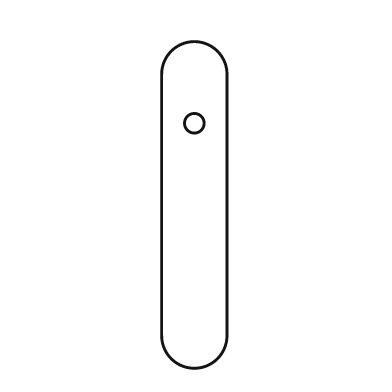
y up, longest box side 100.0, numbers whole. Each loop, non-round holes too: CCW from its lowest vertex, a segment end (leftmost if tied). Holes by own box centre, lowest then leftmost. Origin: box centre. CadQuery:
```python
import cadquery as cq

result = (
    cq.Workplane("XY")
    .moveTo(-10.0, -40.0)
    .threePointArc((0.0, -50.0), (10.0, -40.0))
    .lineTo(10.0, 40.0)
    .threePointArc((0.0, 50.0), (-10.0, 40.0))
    .close()
    .moveTo(0.0, 25.0)
    .circle(3.0)
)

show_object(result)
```